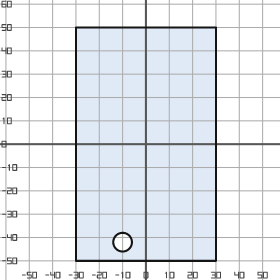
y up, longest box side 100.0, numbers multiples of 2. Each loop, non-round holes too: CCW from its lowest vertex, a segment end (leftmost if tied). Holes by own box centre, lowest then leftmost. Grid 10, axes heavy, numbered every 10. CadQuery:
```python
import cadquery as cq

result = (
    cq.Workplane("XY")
    .moveTo(-30.0, -50.0)
    .lineTo(30.0, -50.0)
    .lineTo(30.0, 50.0)
    .lineTo(-30.0, 50.0)
    .close()
    .moveTo(-10.0, -42.0)
    .circle(4.0)
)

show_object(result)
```